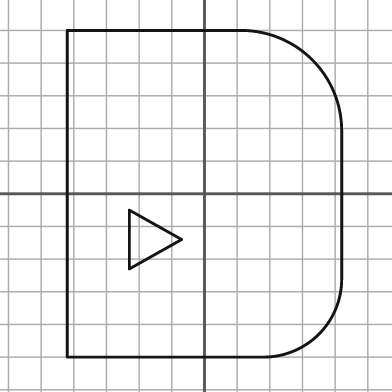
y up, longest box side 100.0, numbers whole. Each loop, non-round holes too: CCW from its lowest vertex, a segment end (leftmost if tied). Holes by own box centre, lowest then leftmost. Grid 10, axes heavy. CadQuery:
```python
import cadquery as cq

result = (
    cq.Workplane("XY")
    .moveTo(-42.0, -50.0)
    .lineTo(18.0, -50.0)
    .threePointArc((35.0, -43.0), (42.0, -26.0))
    .lineTo(42.0, 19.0)
    .threePointArc((33.0, 41.0), (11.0, 50.0))
    .lineTo(-42.0, 50.0)
    .close()
    .moveTo(-23.0, -23.0)
    .lineTo(-7.0, -14.0)
    .lineTo(-23.0, -5.0)
    .close()
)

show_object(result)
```